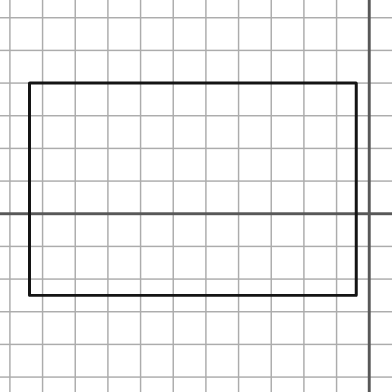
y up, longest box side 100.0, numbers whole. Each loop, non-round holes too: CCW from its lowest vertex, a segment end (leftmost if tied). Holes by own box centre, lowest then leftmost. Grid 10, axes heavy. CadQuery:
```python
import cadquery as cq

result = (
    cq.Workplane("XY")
    .moveTo(-104.0, -25.0)
    .lineTo(-4.0, -25.0)
    .lineTo(-4.0, 40.0)
    .lineTo(-104.0, 40.0)
    .close()
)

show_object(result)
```